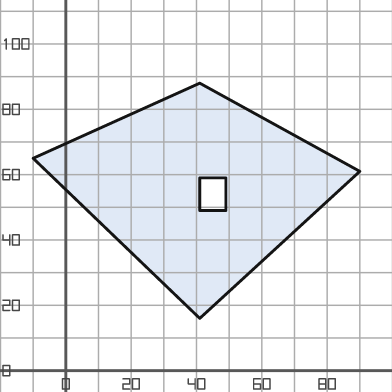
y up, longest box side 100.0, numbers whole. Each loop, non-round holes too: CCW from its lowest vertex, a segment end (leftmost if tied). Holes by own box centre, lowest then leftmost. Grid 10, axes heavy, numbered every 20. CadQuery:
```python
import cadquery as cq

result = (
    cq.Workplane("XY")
    .moveTo(41.0, 16.0)
    .lineTo(90.0, 61.0)
    .lineTo(41.0, 88.0)
    .lineTo(-10.0, 65.0)
    .close()
    .moveTo(41.0, 49.0)
    .lineTo(49.0, 49.0)
    .lineTo(49.0, 59.0)
    .lineTo(41.0, 59.0)
    .close()
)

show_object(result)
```